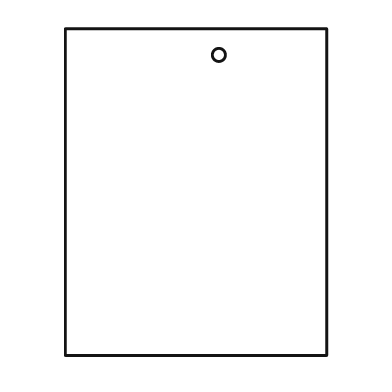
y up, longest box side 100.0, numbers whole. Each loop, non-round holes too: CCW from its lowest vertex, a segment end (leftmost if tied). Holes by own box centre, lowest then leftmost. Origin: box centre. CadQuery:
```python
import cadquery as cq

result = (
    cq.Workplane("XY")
    .moveTo(-40.0, -50.0)
    .lineTo(40.0, -50.0)
    .lineTo(40.0, 50.0)
    .lineTo(-40.0, 50.0)
    .close()
    .moveTo(7.0, 42.0)
    .circle(2.0)
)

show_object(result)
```